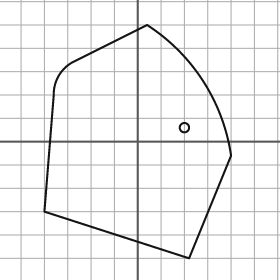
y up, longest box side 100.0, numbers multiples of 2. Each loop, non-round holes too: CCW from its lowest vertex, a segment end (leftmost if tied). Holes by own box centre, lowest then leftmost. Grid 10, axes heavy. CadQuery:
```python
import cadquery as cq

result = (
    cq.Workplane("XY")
    .moveTo(22.0, -50.0)
    .lineTo(40.0, -6.0)
    .threePointArc((28.0, 26.0), (4.0, 50.0))
    .lineTo(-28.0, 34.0)
    .threePointArc((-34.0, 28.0), (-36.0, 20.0))
    .lineTo(-40.0, -30.0)
    .close()
    .moveTo(20.0, 6.0)
    .circle(2.0)
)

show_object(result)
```